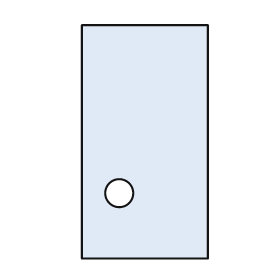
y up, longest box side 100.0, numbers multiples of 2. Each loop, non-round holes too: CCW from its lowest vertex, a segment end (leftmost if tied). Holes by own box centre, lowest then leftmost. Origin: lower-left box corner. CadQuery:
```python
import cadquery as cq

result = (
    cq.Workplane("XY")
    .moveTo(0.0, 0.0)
    .lineTo(54.0, 0.0)
    .lineTo(54.0, 100.0)
    .lineTo(0.0, 100.0)
    .close()
    .moveTo(16.0, 28.0)
    .circle(6.0)
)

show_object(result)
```